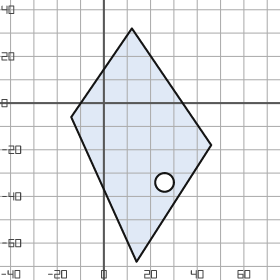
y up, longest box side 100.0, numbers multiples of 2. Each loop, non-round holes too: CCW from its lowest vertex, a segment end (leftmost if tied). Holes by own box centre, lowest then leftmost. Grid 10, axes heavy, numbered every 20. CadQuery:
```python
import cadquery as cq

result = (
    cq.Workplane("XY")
    .moveTo(14.0, -68.0)
    .lineTo(46.0, -18.0)
    .lineTo(12.0, 32.0)
    .lineTo(-14.0, -6.0)
    .close()
    .moveTo(26.0, -34.0)
    .circle(4.0)
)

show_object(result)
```